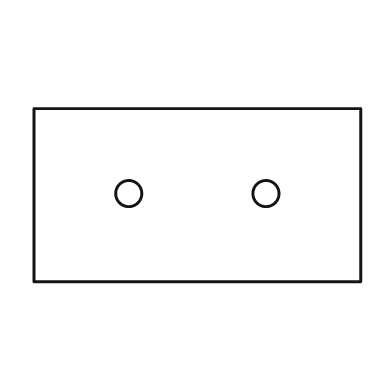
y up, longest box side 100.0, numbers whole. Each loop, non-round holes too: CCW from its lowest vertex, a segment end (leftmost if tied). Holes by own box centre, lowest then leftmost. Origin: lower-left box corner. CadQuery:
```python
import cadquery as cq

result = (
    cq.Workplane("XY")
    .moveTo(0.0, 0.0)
    .lineTo(100.0, 0.0)
    .lineTo(100.0, 53.0)
    .lineTo(0.0, 53.0)
    .close()
    .moveTo(29.0, 27.0)
    .circle(4.0)
    .moveTo(71.0, 27.0)
    .circle(4.0)
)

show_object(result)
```